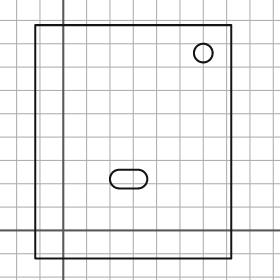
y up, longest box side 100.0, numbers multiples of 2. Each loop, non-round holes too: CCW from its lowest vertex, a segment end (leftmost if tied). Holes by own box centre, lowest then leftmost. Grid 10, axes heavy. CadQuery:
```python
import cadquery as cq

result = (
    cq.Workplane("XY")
    .moveTo(-12.0, -12.0)
    .lineTo(72.0, -12.0)
    .lineTo(72.0, 88.0)
    .lineTo(-12.0, 88.0)
    .close()
    .moveTo(24.0, 18.0)
    .lineTo(32.0, 18.0)
    .threePointArc((36.0, 22.0), (32.0, 26.0))
    .lineTo(24.0, 26.0)
    .threePointArc((20.0, 22.0), (24.0, 18.0))
    .close()
    .moveTo(60.0, 76.0)
    .circle(4.0)
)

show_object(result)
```